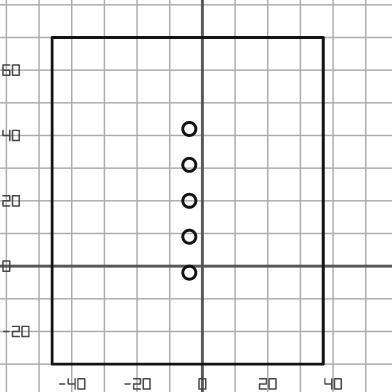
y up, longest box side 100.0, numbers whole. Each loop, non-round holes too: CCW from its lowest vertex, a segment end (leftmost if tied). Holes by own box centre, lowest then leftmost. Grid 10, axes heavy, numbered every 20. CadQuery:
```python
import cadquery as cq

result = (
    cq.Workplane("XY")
    .moveTo(-46.0, -30.0)
    .lineTo(37.0, -30.0)
    .lineTo(37.0, 70.0)
    .lineTo(-46.0, 70.0)
    .close()
    .moveTo(-4.0, -2.0)
    .circle(2.0)
    .moveTo(-4.0, 9.0)
    .circle(2.0)
    .moveTo(-4.0, 20.0)
    .circle(2.0)
    .moveTo(-4.0, 31.0)
    .circle(2.0)
    .moveTo(-4.0, 42.0)
    .circle(2.0)
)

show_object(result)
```